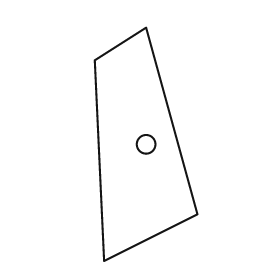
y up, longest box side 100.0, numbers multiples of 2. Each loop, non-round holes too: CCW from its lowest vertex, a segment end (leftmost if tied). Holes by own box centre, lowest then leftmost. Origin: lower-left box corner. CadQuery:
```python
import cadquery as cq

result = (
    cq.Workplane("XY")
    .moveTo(4.0, 0.0)
    .lineTo(44.0, 20.0)
    .lineTo(22.0, 100.0)
    .lineTo(0.0, 86.0)
    .close()
    .moveTo(22.0, 50.0)
    .circle(4.0)
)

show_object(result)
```